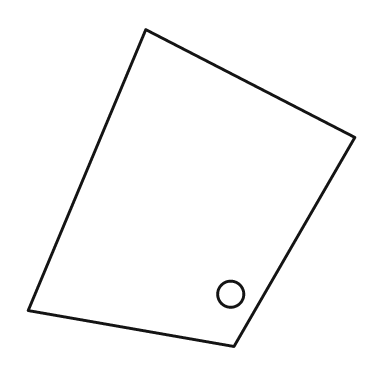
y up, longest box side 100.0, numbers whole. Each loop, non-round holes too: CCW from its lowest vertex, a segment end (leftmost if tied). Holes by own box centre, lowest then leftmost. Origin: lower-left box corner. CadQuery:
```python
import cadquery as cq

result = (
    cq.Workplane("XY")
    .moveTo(63.0, 0.0)
    .lineTo(100.0, 64.0)
    .lineTo(36.0, 97.0)
    .lineTo(0.0, 11.0)
    .close()
    .moveTo(62.0, 16.0)
    .circle(4.0)
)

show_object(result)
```